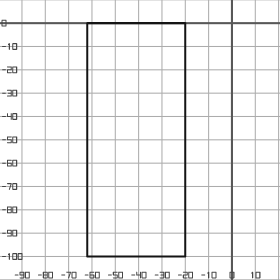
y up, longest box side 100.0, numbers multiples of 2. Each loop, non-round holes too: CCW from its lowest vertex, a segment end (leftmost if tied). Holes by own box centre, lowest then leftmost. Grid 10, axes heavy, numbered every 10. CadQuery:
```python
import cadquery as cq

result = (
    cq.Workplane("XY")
    .moveTo(-62.0, -100.0)
    .lineTo(-20.0, -100.0)
    .lineTo(-20.0, 0.0)
    .lineTo(-62.0, 0.0)
    .close()
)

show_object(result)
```